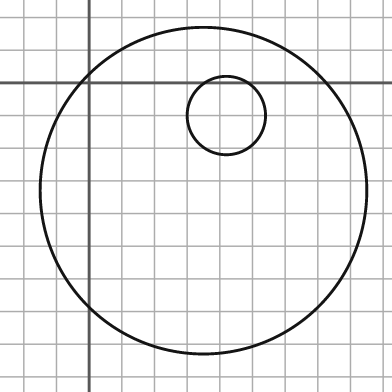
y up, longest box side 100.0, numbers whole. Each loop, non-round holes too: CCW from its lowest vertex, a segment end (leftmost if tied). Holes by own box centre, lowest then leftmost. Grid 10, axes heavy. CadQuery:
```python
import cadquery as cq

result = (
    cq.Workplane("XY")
    .moveTo(35.0, -33.0)
    .circle(50.0)
    .moveTo(42.0, -10.0)
    .circle(12.0)
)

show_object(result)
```